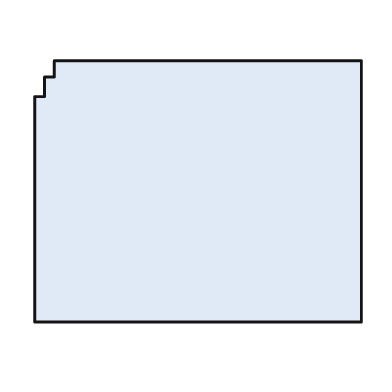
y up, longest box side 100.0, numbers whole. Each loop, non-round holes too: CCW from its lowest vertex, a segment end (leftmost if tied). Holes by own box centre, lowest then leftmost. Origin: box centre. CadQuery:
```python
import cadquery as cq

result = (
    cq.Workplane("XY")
    .moveTo(-50.0, -40.0)
    .lineTo(50.0, -40.0)
    .lineTo(50.0, 40.0)
    .lineTo(-44.0, 40.0)
    .lineTo(-44.0, 35.0)
    .lineTo(-47.0, 35.0)
    .lineTo(-47.0, 29.0)
    .lineTo(-50.0, 29.0)
    .close()
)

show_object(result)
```